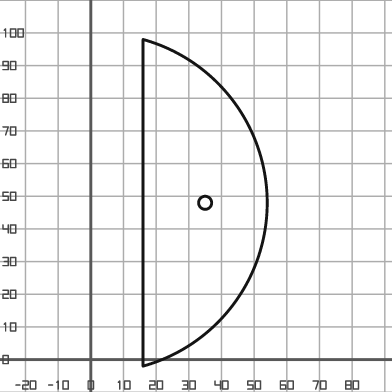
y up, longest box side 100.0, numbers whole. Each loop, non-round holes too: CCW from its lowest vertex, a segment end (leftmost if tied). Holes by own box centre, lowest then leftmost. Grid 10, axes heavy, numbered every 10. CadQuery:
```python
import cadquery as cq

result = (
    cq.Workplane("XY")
    .moveTo(16.0, -2.0)
    .threePointArc((54.0, 48.0), (16.0, 98.0))
    .close()
    .moveTo(35.0, 48.0)
    .circle(2.0)
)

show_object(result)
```